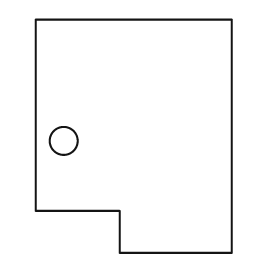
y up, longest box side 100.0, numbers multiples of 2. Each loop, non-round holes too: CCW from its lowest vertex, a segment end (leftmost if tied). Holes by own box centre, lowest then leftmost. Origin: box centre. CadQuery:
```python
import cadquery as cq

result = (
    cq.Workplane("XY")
    .moveTo(-6.0, -50.0)
    .lineTo(42.0, -50.0)
    .lineTo(42.0, 50.0)
    .lineTo(-42.0, 50.0)
    .lineTo(-42.0, -32.0)
    .lineTo(-6.0, -32.0)
    .close()
    .moveTo(-30.0, -2.0)
    .circle(6.0)
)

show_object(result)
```